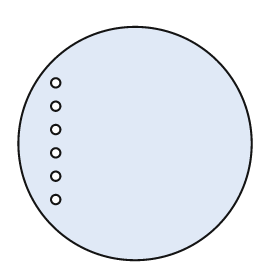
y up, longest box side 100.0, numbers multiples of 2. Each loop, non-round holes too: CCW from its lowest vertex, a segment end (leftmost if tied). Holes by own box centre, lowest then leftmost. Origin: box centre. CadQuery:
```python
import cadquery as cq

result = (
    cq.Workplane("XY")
    .moveTo(0.0, 0.0)
    .circle(50.0)
    .moveTo(-34.0, -24.0)
    .circle(2.0)
    .moveTo(-34.0, -14.0)
    .circle(2.0)
    .moveTo(-34.0, -4.0)
    .circle(2.0)
    .moveTo(-34.0, 6.0)
    .circle(2.0)
    .moveTo(-34.0, 16.0)
    .circle(2.0)
    .moveTo(-34.0, 26.0)
    .circle(2.0)
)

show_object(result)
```